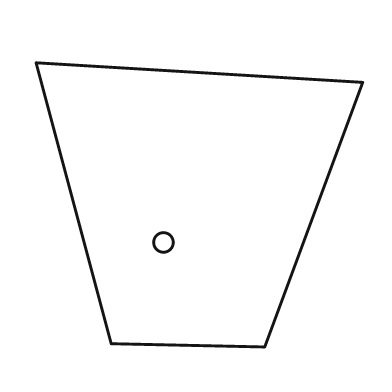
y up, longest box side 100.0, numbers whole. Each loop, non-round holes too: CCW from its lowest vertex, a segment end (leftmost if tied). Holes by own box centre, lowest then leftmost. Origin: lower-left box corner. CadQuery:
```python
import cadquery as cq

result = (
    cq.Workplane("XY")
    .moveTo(70.0, 0.0)
    .lineTo(100.0, 81.0)
    .lineTo(0.0, 87.0)
    .lineTo(23.0, 1.0)
    .close()
    .moveTo(39.0, 32.0)
    .circle(3.0)
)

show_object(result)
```